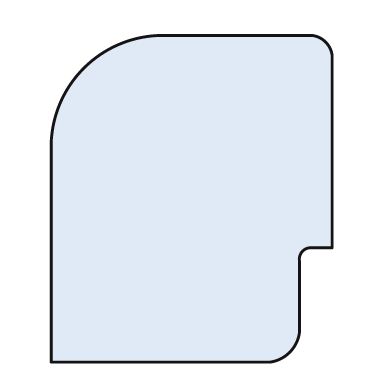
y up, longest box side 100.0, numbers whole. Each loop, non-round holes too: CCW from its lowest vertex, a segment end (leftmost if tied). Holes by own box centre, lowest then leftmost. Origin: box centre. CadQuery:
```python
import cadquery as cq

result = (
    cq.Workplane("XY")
    .moveTo(-43.0, -50.0)
    .lineTo(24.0, -50.0)
    .threePointArc((30.0, -47.0), (33.0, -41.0))
    .lineTo(33.0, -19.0)
    .threePointArc((34.0, -16.0), (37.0, -15.0))
    .lineTo(43.0, -15.0)
    .lineTo(43.0, 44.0)
    .threePointArc((41.0, 48.0), (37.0, 50.0))
    .lineTo(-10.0, 50.0)
    .threePointArc((-33.0, 40.0), (-43.0, 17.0))
    .close()
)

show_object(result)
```